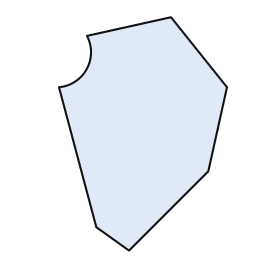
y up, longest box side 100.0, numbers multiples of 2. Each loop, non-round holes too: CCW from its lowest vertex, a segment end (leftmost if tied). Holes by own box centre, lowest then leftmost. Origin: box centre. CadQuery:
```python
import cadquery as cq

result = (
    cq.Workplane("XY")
    .moveTo(-6.0, -50.0)
    .lineTo(28.0, -16.0)
    .lineTo(36.0, 20.0)
    .lineTo(12.0, 50.0)
    .lineTo(-24.0, 42.0)
    .threePointArc((-24.0, 28.0), (-36.0, 20.0))
    .lineTo(-20.0, -40.0)
    .close()
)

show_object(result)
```